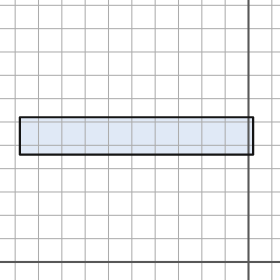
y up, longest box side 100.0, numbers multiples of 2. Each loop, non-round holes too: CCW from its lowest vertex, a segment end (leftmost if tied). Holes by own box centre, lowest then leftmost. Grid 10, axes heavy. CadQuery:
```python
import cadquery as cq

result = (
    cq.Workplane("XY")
    .moveTo(-98.0, 46.0)
    .lineTo(2.0, 46.0)
    .lineTo(2.0, 62.0)
    .lineTo(-98.0, 62.0)
    .close()
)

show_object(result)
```